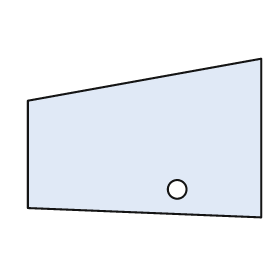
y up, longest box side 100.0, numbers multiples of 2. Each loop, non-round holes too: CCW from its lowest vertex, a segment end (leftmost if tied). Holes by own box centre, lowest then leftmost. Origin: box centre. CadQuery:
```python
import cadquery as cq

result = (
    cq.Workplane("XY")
    .moveTo(50.0, -34.0)
    .lineTo(50.0, 34.0)
    .lineTo(-50.0, 16.0)
    .lineTo(-50.0, -30.0)
    .close()
    .moveTo(14.0, -22.0)
    .circle(4.0)
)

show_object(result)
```